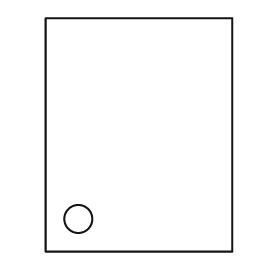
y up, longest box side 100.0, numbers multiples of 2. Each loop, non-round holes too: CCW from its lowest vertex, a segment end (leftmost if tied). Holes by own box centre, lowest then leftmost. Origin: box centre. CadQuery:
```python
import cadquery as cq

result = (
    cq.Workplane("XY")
    .moveTo(-40.0, -50.0)
    .lineTo(40.0, -50.0)
    .lineTo(40.0, 50.0)
    .lineTo(-40.0, 50.0)
    .close()
    .moveTo(-26.0, -36.0)
    .circle(6.0)
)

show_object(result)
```